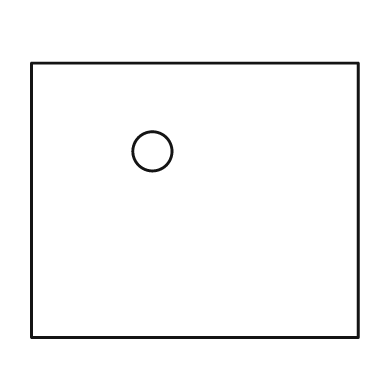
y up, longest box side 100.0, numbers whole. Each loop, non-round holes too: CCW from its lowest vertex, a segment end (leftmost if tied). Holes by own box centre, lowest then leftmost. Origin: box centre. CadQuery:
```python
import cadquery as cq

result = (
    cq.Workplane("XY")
    .moveTo(-50.0, -42.0)
    .lineTo(50.0, -42.0)
    .lineTo(50.0, 42.0)
    .lineTo(-50.0, 42.0)
    .close()
    .moveTo(-13.0, 15.0)
    .circle(6.0)
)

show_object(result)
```